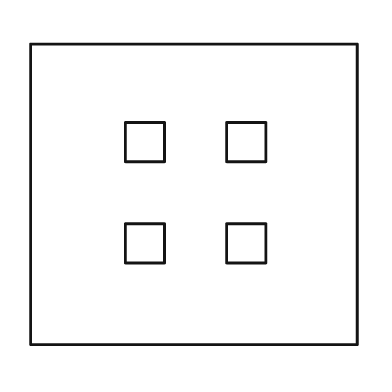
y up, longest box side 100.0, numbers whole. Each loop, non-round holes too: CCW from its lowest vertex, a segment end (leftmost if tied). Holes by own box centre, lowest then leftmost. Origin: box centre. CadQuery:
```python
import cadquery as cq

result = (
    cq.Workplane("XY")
    .moveTo(-50.0, -46.0)
    .lineTo(50.0, -46.0)
    .lineTo(50.0, 46.0)
    .lineTo(-50.0, 46.0)
    .close()
    .moveTo(-21.0, -21.0)
    .lineTo(-9.0, -21.0)
    .lineTo(-9.0, -9.0)
    .lineTo(-21.0, -9.0)
    .close()
    .moveTo(10.0, -21.0)
    .lineTo(22.0, -21.0)
    .lineTo(22.0, -9.0)
    .lineTo(10.0, -9.0)
    .close()
    .moveTo(-21.0, 10.0)
    .lineTo(-9.0, 10.0)
    .lineTo(-9.0, 22.0)
    .lineTo(-21.0, 22.0)
    .close()
    .moveTo(10.0, 10.0)
    .lineTo(22.0, 10.0)
    .lineTo(22.0, 22.0)
    .lineTo(10.0, 22.0)
    .close()
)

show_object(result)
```